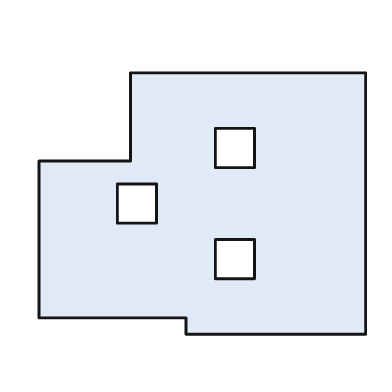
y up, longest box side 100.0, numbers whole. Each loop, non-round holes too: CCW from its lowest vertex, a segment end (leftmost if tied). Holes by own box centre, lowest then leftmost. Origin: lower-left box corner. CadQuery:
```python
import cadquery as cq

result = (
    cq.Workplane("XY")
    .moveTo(45.0, 0.0)
    .lineTo(100.0, 0.0)
    .lineTo(100.0, 80.0)
    .lineTo(28.0, 80.0)
    .lineTo(28.0, 53.0)
    .lineTo(0.0, 53.0)
    .lineTo(0.0, 5.0)
    .lineTo(45.0, 5.0)
    .close()
    .moveTo(54.0, 17.0)
    .lineTo(66.0, 17.0)
    .lineTo(66.0, 29.0)
    .lineTo(54.0, 29.0)
    .close()
    .moveTo(24.0, 34.0)
    .lineTo(36.0, 34.0)
    .lineTo(36.0, 46.0)
    .lineTo(24.0, 46.0)
    .close()
    .moveTo(54.0, 51.0)
    .lineTo(66.0, 51.0)
    .lineTo(66.0, 63.0)
    .lineTo(54.0, 63.0)
    .close()
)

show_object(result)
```